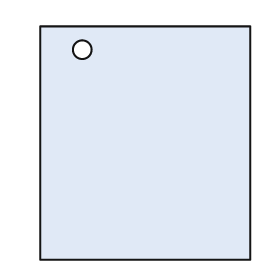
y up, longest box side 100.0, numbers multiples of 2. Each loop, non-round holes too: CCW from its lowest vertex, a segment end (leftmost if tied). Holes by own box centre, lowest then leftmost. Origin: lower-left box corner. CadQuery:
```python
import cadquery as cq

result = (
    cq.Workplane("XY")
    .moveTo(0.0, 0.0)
    .lineTo(90.0, 0.0)
    .lineTo(90.0, 100.0)
    .lineTo(0.0, 100.0)
    .close()
    .moveTo(18.0, 90.0)
    .circle(4.0)
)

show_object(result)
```